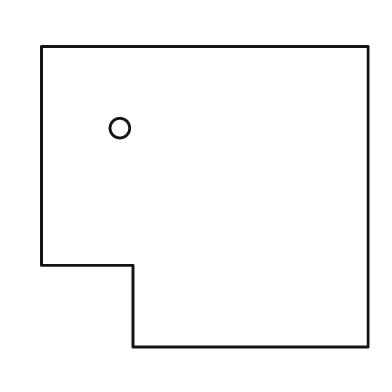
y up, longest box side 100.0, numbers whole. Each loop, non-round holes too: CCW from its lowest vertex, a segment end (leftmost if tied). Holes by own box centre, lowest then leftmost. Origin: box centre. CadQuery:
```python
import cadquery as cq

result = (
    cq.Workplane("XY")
    .moveTo(-22.0, -46.0)
    .lineTo(50.0, -46.0)
    .lineTo(50.0, 46.0)
    .lineTo(-50.0, 46.0)
    .lineTo(-50.0, -21.0)
    .lineTo(-22.0, -21.0)
    .close()
    .moveTo(-26.0, 21.0)
    .circle(3.0)
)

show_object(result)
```